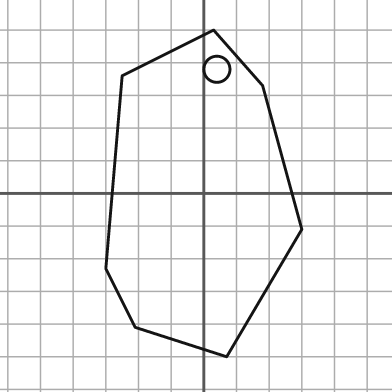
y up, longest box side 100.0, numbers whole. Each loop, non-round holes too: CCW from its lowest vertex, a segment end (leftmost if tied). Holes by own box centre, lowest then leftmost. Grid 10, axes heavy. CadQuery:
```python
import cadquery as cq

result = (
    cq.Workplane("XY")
    .moveTo(7.0, -50.0)
    .lineTo(30.0, -11.0)
    .lineTo(18.0, 33.0)
    .lineTo(3.0, 50.0)
    .lineTo(-25.0, 36.0)
    .lineTo(-30.0, -23.0)
    .lineTo(-21.0, -41.0)
    .close()
    .moveTo(4.0, 38.0)
    .circle(4.0)
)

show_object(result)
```